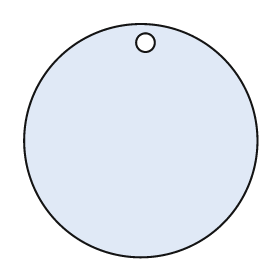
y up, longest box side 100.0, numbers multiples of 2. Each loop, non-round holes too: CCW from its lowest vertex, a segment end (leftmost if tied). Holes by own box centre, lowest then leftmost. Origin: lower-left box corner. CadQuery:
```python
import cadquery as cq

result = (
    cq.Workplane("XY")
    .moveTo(50.0, 50.0)
    .circle(50.0)
    .moveTo(52.0, 92.0)
    .circle(4.0)
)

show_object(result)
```